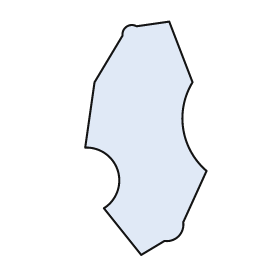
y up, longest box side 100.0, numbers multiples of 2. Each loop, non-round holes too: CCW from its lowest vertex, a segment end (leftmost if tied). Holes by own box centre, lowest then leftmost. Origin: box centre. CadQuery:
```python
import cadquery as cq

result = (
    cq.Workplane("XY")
    .moveTo(-2.0, -50.0)
    .lineTo(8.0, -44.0)
    .threePointArc((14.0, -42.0), (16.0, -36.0))
    .lineTo(26.0, -14.0)
    .threePointArc((16.0, 4.0), (20.0, 24.0))
    .lineTo(10.0, 50.0)
    .lineTo(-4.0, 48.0)
    .threePointArc((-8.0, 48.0), (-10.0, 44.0))
    .lineTo(-22.0, 24.0)
    .lineTo(-26.0, -4.0)
    .threePointArc((-12.0, -14.0), (-18.0, -30.0))
    .close()
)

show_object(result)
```